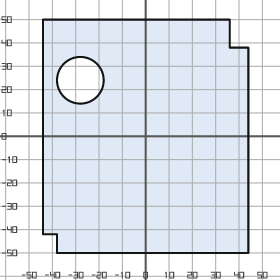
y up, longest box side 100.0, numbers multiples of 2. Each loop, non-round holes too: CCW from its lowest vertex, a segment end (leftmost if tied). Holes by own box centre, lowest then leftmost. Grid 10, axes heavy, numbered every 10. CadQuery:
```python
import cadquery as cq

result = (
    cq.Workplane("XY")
    .moveTo(-38.0, -50.0)
    .lineTo(44.0, -50.0)
    .lineTo(44.0, 38.0)
    .lineTo(36.0, 38.0)
    .lineTo(36.0, 50.0)
    .lineTo(-44.0, 50.0)
    .lineTo(-44.0, -42.0)
    .lineTo(-38.0, -42.0)
    .close()
    .moveTo(-28.0, 24.0)
    .circle(10.0)
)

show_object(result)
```